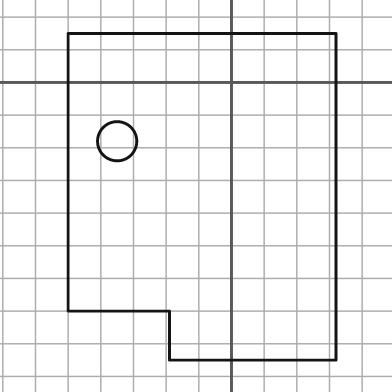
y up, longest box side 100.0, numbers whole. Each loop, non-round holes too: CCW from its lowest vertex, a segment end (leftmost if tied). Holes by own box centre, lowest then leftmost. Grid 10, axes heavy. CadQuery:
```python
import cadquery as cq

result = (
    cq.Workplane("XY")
    .moveTo(-19.0, -85.0)
    .lineTo(32.0, -85.0)
    .lineTo(32.0, 15.0)
    .lineTo(-50.0, 15.0)
    .lineTo(-50.0, -70.0)
    .lineTo(-19.0, -70.0)
    .close()
    .moveTo(-35.0, -18.0)
    .circle(6.0)
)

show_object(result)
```